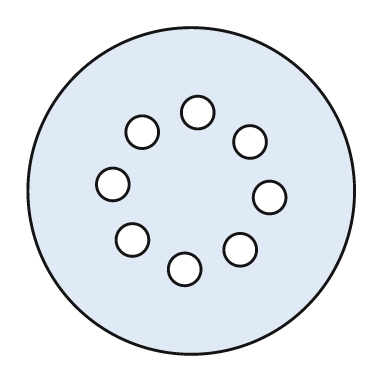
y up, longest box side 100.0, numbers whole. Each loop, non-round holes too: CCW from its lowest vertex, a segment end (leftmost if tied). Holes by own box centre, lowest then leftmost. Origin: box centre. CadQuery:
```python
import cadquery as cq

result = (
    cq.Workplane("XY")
    .moveTo(0.0, 0.0)
    .circle(50.0)
    .moveTo(-2.0, -24.0)
    .circle(5.0)
    .moveTo(15.0, -18.0)
    .circle(5.0)
    .moveTo(-18.0, -15.0)
    .circle(5.0)
    .moveTo(24.0, -2.0)
    .circle(5.0)
    .moveTo(-24.0, 2.0)
    .circle(5.0)
    .moveTo(18.0, 15.0)
    .circle(5.0)
    .moveTo(-15.0, 18.0)
    .circle(5.0)
    .moveTo(2.0, 24.0)
    .circle(5.0)
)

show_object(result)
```